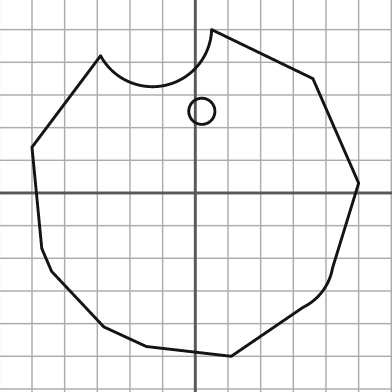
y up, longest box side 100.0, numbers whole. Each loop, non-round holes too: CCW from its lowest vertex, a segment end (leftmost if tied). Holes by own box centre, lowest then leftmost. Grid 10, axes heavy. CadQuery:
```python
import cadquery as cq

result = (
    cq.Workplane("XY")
    .moveTo(11.0, -50.0)
    .lineTo(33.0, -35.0)
    .threePointArc((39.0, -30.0), (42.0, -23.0))
    .lineTo(50.0, 3.0)
    .lineTo(36.0, 35.0)
    .lineTo(5.0, 50.0)
    .threePointArc((-9.0, 33.0), (-29.0, 42.0))
    .lineTo(-50.0, 14.0)
    .lineTo(-47.0, -17.0)
    .lineTo(-44.0, -24.0)
    .lineTo(-28.0, -41.0)
    .lineTo(-15.0, -47.0)
    .close()
    .moveTo(2.0, 25.0)
    .circle(4.0)
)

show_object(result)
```